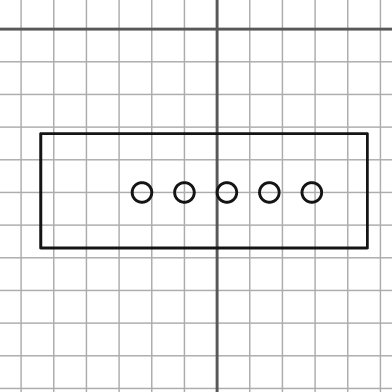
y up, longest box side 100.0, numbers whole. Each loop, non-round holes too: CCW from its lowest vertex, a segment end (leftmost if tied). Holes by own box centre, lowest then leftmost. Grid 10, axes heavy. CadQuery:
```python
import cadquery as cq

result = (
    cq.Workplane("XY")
    .moveTo(-54.0, -67.0)
    .lineTo(46.0, -67.0)
    .lineTo(46.0, -32.0)
    .lineTo(-54.0, -32.0)
    .close()
    .moveTo(-23.0, -50.0)
    .circle(3.0)
    .moveTo(-10.0, -50.0)
    .circle(3.0)
    .moveTo(3.0, -50.0)
    .circle(3.0)
    .moveTo(16.0, -50.0)
    .circle(3.0)
    .moveTo(29.0, -50.0)
    .circle(3.0)
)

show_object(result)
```